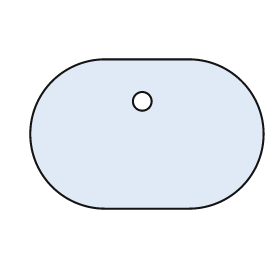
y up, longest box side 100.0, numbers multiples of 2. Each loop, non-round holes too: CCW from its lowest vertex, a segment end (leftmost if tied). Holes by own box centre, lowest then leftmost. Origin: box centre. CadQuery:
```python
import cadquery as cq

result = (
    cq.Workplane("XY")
    .moveTo(-18.0, -32.0)
    .lineTo(18.0, -32.0)
    .threePointArc((50.0, 0.0), (18.0, 32.0))
    .lineTo(-18.0, 32.0)
    .threePointArc((-50.0, 0.0), (-18.0, -32.0))
    .close()
    .moveTo(-2.0, 14.0)
    .circle(4.0)
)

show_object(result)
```